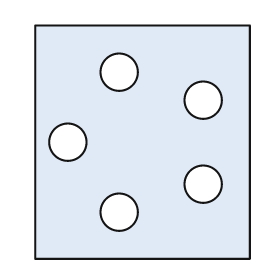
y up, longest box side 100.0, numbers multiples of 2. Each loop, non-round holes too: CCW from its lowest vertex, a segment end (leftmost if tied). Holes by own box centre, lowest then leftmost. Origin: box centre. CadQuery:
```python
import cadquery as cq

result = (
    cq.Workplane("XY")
    .moveTo(-46.0, -50.0)
    .lineTo(46.0, -50.0)
    .lineTo(46.0, 50.0)
    .lineTo(-46.0, 50.0)
    .close()
    .moveTo(-10.0, -30.0)
    .circle(8.0)
    .moveTo(26.0, -18.0)
    .circle(8.0)
    .moveTo(-32.0, 0.0)
    .circle(8.0)
    .moveTo(26.0, 18.0)
    .circle(8.0)
    .moveTo(-10.0, 30.0)
    .circle(8.0)
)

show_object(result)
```